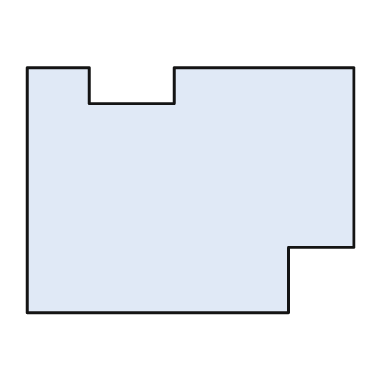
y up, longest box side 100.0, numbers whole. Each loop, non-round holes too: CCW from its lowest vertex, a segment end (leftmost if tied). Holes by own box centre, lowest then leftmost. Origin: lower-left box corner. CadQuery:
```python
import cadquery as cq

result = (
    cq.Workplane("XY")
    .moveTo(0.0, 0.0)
    .lineTo(80.0, 0.0)
    .lineTo(80.0, 20.0)
    .lineTo(100.0, 20.0)
    .lineTo(100.0, 75.0)
    .lineTo(45.0, 75.0)
    .lineTo(45.0, 64.0)
    .lineTo(19.0, 64.0)
    .lineTo(19.0, 75.0)
    .lineTo(0.0, 75.0)
    .close()
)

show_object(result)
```